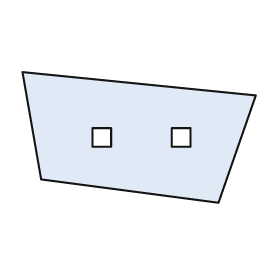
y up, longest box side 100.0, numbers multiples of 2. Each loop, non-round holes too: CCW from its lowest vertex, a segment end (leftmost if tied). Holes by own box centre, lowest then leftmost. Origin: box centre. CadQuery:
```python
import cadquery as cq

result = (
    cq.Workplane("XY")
    .moveTo(34.0, -28.0)
    .lineTo(50.0, 18.0)
    .lineTo(-50.0, 28.0)
    .lineTo(-42.0, -18.0)
    .close()
    .moveTo(-20.0, -4.0)
    .lineTo(-12.0, -4.0)
    .lineTo(-12.0, 4.0)
    .lineTo(-20.0, 4.0)
    .close()
    .moveTo(14.0, -4.0)
    .lineTo(22.0, -4.0)
    .lineTo(22.0, 4.0)
    .lineTo(14.0, 4.0)
    .close()
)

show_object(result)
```